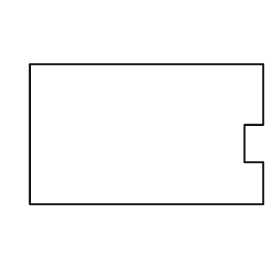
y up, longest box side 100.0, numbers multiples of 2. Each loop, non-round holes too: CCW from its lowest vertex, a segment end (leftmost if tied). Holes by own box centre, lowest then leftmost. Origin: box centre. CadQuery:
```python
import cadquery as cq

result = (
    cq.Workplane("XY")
    .moveTo(-50.0, -30.0)
    .lineTo(50.0, -30.0)
    .lineTo(50.0, -12.0)
    .lineTo(42.0, -12.0)
    .lineTo(42.0, 4.0)
    .lineTo(50.0, 4.0)
    .lineTo(50.0, 30.0)
    .lineTo(-50.0, 30.0)
    .close()
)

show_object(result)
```